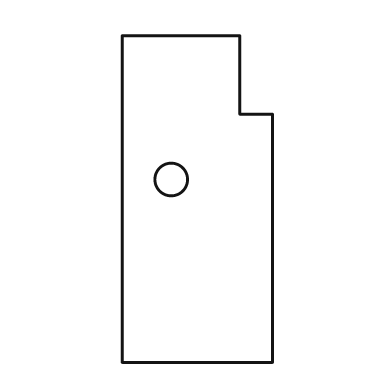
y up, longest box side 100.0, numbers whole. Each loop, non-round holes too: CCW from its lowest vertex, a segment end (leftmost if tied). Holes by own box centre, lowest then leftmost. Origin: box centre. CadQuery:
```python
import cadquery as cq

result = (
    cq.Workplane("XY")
    .moveTo(-23.0, -50.0)
    .lineTo(23.0, -50.0)
    .lineTo(23.0, 26.0)
    .lineTo(13.0, 26.0)
    .lineTo(13.0, 50.0)
    .lineTo(-23.0, 50.0)
    .close()
    .moveTo(-8.0, 6.0)
    .circle(5.0)
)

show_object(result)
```